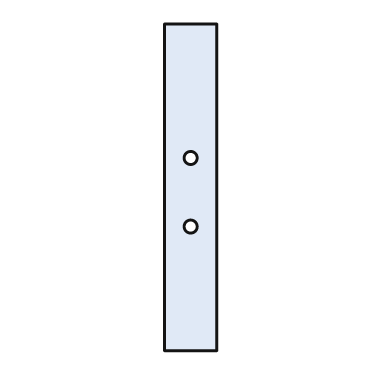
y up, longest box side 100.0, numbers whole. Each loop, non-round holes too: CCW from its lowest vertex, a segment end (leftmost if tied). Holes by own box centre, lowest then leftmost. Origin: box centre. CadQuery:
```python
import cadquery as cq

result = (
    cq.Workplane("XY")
    .moveTo(-8.0, -50.0)
    .lineTo(8.0, -50.0)
    .lineTo(8.0, 50.0)
    .lineTo(-8.0, 50.0)
    .close()
    .moveTo(0.0, -12.0)
    .circle(2.0)
    .moveTo(0.0, 9.0)
    .circle(2.0)
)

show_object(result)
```